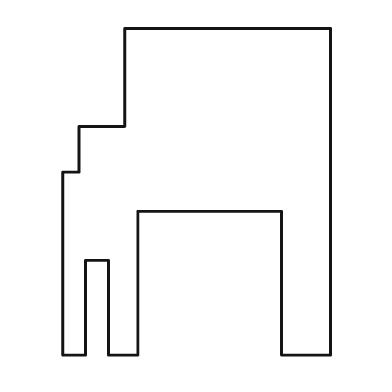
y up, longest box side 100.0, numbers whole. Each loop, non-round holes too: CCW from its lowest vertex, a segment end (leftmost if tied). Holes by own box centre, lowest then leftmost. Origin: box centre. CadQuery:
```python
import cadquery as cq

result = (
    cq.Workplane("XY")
    .moveTo(-41.0, -50.0)
    .lineTo(-34.0, -50.0)
    .lineTo(-34.0, -21.0)
    .lineTo(-27.0, -21.0)
    .lineTo(-27.0, -50.0)
    .lineTo(-18.0, -50.0)
    .lineTo(-18.0, -6.0)
    .lineTo(26.0, -6.0)
    .lineTo(26.0, -50.0)
    .lineTo(41.0, -50.0)
    .lineTo(41.0, 50.0)
    .lineTo(-22.0, 50.0)
    .lineTo(-22.0, 20.0)
    .lineTo(-36.0, 20.0)
    .lineTo(-36.0, 6.0)
    .lineTo(-41.0, 6.0)
    .close()
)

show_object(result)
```